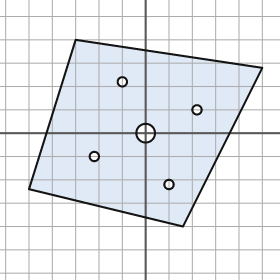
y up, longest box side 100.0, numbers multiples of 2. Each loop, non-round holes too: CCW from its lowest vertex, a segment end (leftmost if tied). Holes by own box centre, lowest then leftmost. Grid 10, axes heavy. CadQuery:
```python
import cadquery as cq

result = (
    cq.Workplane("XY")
    .moveTo(16.0, -40.0)
    .lineTo(50.0, 28.0)
    .lineTo(-30.0, 40.0)
    .lineTo(-50.0, -24.0)
    .close()
    .moveTo(10.0, -22.0)
    .circle(2.0)
    .moveTo(-22.0, -10.0)
    .circle(2.0)
    .moveTo(0.0, 0.0)
    .circle(4.0)
    .moveTo(22.0, 10.0)
    .circle(2.0)
    .moveTo(-10.0, 22.0)
    .circle(2.0)
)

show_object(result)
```